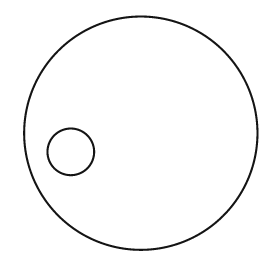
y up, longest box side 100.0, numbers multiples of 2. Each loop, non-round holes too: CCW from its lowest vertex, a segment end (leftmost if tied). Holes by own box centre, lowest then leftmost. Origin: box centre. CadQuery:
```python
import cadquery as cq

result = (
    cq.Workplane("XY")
    .moveTo(0.0, 0.0)
    .circle(50.0)
    .moveTo(-30.0, -8.0)
    .circle(10.0)
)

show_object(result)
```